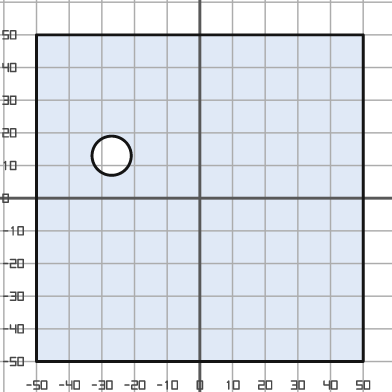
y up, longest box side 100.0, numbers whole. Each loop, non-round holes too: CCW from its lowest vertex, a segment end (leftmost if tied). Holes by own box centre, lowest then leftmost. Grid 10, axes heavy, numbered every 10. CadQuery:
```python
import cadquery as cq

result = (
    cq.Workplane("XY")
    .moveTo(-50.0, -50.0)
    .lineTo(50.0, -50.0)
    .lineTo(50.0, 50.0)
    .lineTo(-50.0, 50.0)
    .close()
    .moveTo(-27.0, 13.0)
    .circle(6.0)
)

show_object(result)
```